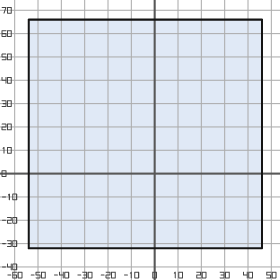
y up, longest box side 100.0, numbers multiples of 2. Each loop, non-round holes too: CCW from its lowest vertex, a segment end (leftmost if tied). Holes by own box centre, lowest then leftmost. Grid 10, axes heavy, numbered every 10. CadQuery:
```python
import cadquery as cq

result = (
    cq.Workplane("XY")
    .moveTo(-54.0, -32.0)
    .lineTo(46.0, -32.0)
    .lineTo(46.0, 66.0)
    .lineTo(-54.0, 66.0)
    .close()
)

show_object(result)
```